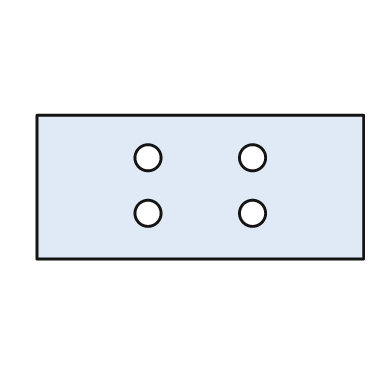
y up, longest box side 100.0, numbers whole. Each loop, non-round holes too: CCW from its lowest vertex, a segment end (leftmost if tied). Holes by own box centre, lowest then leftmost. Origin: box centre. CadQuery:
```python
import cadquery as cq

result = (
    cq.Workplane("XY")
    .moveTo(-50.0, -22.0)
    .lineTo(50.0, -22.0)
    .lineTo(50.0, 22.0)
    .lineTo(-50.0, 22.0)
    .close()
    .moveTo(-16.0, -8.0)
    .circle(4.0)
    .moveTo(16.0, -8.0)
    .circle(4.0)
    .moveTo(-16.0, 9.0)
    .circle(4.0)
    .moveTo(16.0, 9.0)
    .circle(4.0)
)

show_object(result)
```